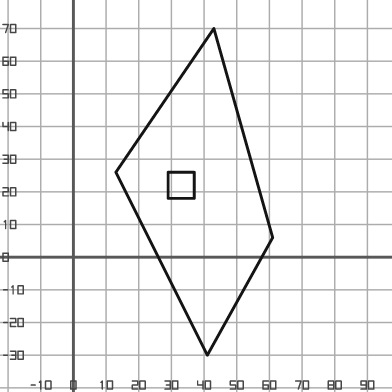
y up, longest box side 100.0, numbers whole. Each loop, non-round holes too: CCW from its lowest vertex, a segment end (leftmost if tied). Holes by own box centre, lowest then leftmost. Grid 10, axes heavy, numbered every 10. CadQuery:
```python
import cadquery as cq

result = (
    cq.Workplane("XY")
    .moveTo(41.0, -30.0)
    .lineTo(61.0, 6.0)
    .lineTo(43.0, 70.0)
    .lineTo(13.0, 26.0)
    .close()
    .moveTo(29.0, 18.0)
    .lineTo(37.0, 18.0)
    .lineTo(37.0, 26.0)
    .lineTo(29.0, 26.0)
    .close()
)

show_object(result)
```